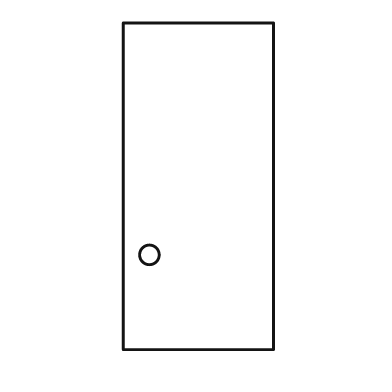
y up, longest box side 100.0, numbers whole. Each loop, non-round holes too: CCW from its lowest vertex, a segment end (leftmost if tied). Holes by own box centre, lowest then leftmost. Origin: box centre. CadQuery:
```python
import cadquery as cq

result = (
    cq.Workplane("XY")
    .moveTo(-23.0, -50.0)
    .lineTo(23.0, -50.0)
    .lineTo(23.0, 50.0)
    .lineTo(-23.0, 50.0)
    .close()
    .moveTo(-15.0, -21.0)
    .circle(3.0)
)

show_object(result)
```